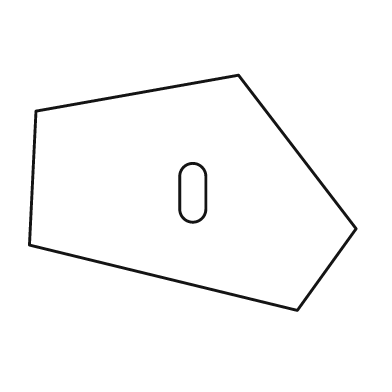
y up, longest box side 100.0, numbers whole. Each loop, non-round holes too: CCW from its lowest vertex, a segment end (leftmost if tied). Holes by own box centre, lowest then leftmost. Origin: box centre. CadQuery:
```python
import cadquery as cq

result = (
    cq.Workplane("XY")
    .moveTo(32.0, -36.0)
    .lineTo(50.0, -11.0)
    .lineTo(14.0, 36.0)
    .lineTo(-48.0, 25.0)
    .lineTo(-50.0, -16.0)
    .close()
    .moveTo(-4.0, -5.0)
    .threePointArc((0.0, -9.0), (4.0, -5.0))
    .lineTo(4.0, 5.0)
    .threePointArc((0.0, 9.0), (-4.0, 5.0))
    .close()
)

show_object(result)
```